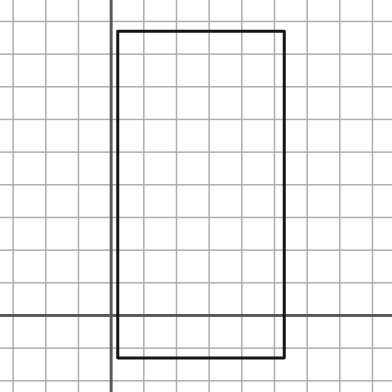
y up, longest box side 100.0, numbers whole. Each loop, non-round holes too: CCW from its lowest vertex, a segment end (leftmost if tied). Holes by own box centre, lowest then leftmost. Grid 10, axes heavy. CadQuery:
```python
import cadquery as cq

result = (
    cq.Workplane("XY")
    .moveTo(2.0, -13.0)
    .lineTo(53.0, -13.0)
    .lineTo(53.0, 87.0)
    .lineTo(2.0, 87.0)
    .close()
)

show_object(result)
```